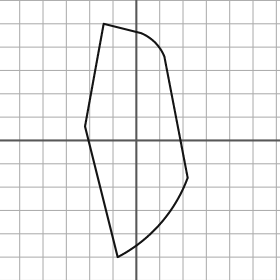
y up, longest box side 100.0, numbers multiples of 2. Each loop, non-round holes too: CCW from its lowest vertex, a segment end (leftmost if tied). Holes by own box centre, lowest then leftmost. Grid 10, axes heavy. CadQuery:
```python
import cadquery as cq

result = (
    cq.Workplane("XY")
    .moveTo(-8.0, -50.0)
    .threePointArc((10.0, -36.0), (22.0, -16.0))
    .lineTo(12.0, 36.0)
    .threePointArc((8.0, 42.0), (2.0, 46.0))
    .lineTo(-14.0, 50.0)
    .lineTo(-22.0, 6.0)
    .close()
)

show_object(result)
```